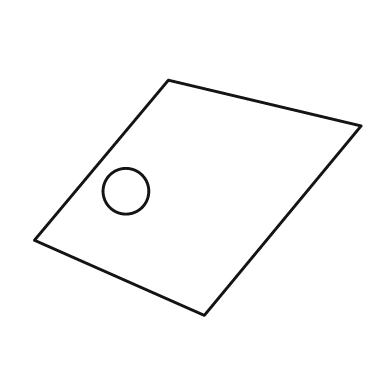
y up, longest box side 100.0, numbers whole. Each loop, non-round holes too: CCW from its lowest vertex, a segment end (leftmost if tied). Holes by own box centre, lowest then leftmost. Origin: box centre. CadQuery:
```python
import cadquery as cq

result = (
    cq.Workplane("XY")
    .moveTo(2.0, -36.0)
    .lineTo(50.0, 22.0)
    .lineTo(-9.0, 36.0)
    .lineTo(-50.0, -13.0)
    .close()
    .moveTo(-22.0, 2.0)
    .circle(7.0)
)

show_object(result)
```